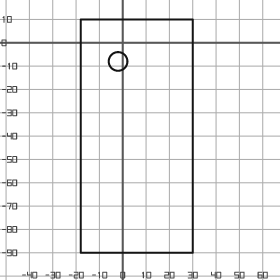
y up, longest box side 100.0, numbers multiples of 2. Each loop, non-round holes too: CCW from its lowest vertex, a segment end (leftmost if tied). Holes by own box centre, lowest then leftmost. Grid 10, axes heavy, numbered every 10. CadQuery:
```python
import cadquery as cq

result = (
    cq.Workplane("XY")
    .moveTo(-18.0, -90.0)
    .lineTo(30.0, -90.0)
    .lineTo(30.0, 10.0)
    .lineTo(-18.0, 10.0)
    .close()
    .moveTo(-2.0, -8.0)
    .circle(4.0)
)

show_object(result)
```